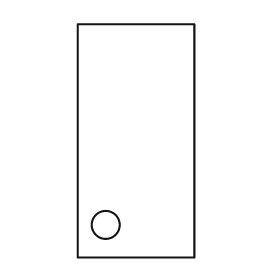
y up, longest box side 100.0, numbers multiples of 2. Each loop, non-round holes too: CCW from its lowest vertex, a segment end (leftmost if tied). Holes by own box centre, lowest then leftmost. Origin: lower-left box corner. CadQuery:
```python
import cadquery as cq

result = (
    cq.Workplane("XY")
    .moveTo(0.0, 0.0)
    .lineTo(50.0, 0.0)
    .lineTo(50.0, 100.0)
    .lineTo(0.0, 100.0)
    .close()
    .moveTo(12.0, 14.0)
    .circle(6.0)
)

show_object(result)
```